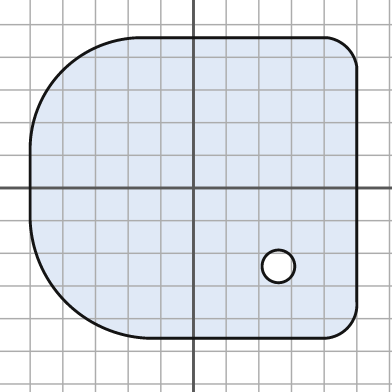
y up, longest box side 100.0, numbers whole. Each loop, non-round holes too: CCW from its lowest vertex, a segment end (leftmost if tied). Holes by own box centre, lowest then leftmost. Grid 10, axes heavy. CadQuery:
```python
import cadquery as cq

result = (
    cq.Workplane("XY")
    .moveTo(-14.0, -46.0)
    .lineTo(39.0, -46.0)
    .threePointArc((47.0, -43.0), (50.0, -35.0))
    .lineTo(50.0, 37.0)
    .threePointArc((47.0, 43.0), (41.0, 46.0))
    .lineTo(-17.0, 46.0)
    .threePointArc((-40.0, 36.0), (-50.0, 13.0))
    .lineTo(-50.0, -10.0)
    .threePointArc((-39.0, -35.0), (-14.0, -46.0))
    .close()
    .moveTo(26.0, -24.0)
    .circle(5.0)
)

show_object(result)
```